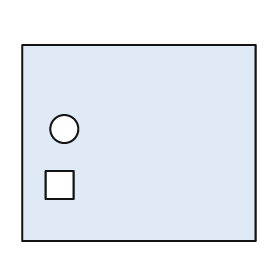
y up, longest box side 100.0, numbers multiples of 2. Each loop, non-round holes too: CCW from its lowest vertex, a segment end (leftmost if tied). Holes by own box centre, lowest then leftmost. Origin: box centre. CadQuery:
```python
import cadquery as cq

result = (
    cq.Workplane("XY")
    .moveTo(-50.0, -42.0)
    .lineTo(50.0, -42.0)
    .lineTo(50.0, 42.0)
    .lineTo(-50.0, 42.0)
    .close()
    .moveTo(-40.0, -24.0)
    .lineTo(-28.0, -24.0)
    .lineTo(-28.0, -12.0)
    .lineTo(-40.0, -12.0)
    .close()
    .moveTo(-32.0, 6.0)
    .circle(6.0)
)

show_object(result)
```